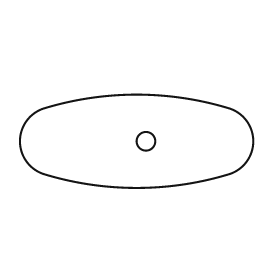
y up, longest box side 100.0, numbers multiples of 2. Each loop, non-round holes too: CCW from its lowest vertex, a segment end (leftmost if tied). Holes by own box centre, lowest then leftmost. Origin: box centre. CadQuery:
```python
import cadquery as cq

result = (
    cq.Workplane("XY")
    .moveTo(-40.0, -14.0)
    .threePointArc((0.0, -20.0), (40.0, -14.0))
    .threePointArc((50.0, 0.0), (40.0, 14.0))
    .threePointArc((0.0, 20.0), (-40.0, 14.0))
    .threePointArc((-50.0, 0.0), (-40.0, -14.0))
    .close()
    .moveTo(4.0, 0.0)
    .circle(4.0)
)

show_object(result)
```